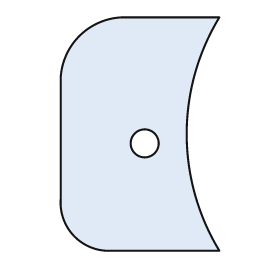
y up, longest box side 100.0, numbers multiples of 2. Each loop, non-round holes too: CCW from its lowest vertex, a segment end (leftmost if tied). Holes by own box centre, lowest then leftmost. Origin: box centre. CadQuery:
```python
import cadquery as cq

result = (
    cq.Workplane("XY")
    .moveTo(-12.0, -50.0)
    .lineTo(34.0, -50.0)
    .threePointArc((20.0, 0.0), (34.0, 50.0))
    .lineTo(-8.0, 50.0)
    .threePointArc((-26.0, 42.0), (-34.0, 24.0))
    .lineTo(-34.0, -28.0)
    .threePointArc((-28.0, -44.0), (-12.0, -50.0))
    .close()
    .moveTo(2.0, -4.0)
    .circle(6.0)
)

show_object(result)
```